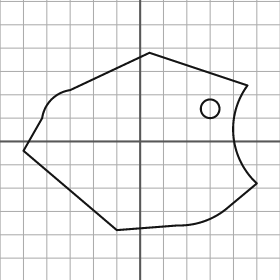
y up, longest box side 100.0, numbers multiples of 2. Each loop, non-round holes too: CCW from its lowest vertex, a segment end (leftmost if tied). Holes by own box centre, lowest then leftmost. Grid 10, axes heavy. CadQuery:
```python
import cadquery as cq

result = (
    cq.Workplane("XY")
    .moveTo(-10.0, -38.0)
    .lineTo(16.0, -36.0)
    .threePointArc((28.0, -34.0), (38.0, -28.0))
    .lineTo(50.0, -18.0)
    .threePointArc((40.0, 2.0), (46.0, 24.0))
    .lineTo(4.0, 38.0)
    .lineTo(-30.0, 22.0)
    .threePointArc((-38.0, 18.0), (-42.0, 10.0))
    .lineTo(-50.0, -4.0)
    .close()
    .moveTo(30.0, 14.0)
    .circle(4.0)
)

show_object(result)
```